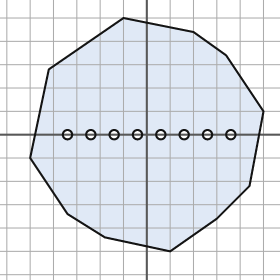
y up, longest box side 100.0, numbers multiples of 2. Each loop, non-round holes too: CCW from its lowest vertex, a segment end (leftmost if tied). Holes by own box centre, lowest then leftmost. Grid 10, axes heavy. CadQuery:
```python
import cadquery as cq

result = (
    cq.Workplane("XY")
    .moveTo(10.0, -50.0)
    .lineTo(30.0, -36.0)
    .lineTo(44.0, -22.0)
    .lineTo(50.0, 10.0)
    .lineTo(34.0, 34.0)
    .lineTo(20.0, 44.0)
    .lineTo(-10.0, 50.0)
    .lineTo(-42.0, 28.0)
    .lineTo(-50.0, -10.0)
    .lineTo(-34.0, -34.0)
    .lineTo(-18.0, -44.0)
    .close()
    .moveTo(-34.0, 0.0)
    .circle(2.0)
    .moveTo(-24.0, 0.0)
    .circle(2.0)
    .moveTo(-14.0, 0.0)
    .circle(2.0)
    .moveTo(-4.0, 0.0)
    .circle(2.0)
    .moveTo(6.0, 0.0)
    .circle(2.0)
    .moveTo(16.0, 0.0)
    .circle(2.0)
    .moveTo(26.0, 0.0)
    .circle(2.0)
    .moveTo(36.0, 0.0)
    .circle(2.0)
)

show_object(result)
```